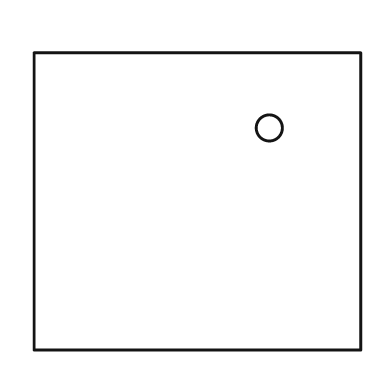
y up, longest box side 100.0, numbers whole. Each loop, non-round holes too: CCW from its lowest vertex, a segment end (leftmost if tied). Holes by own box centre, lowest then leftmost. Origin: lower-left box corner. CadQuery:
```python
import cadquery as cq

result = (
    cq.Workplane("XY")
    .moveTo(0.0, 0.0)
    .lineTo(100.0, 0.0)
    .lineTo(100.0, 91.0)
    .lineTo(0.0, 91.0)
    .close()
    .moveTo(72.0, 68.0)
    .circle(4.0)
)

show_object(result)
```